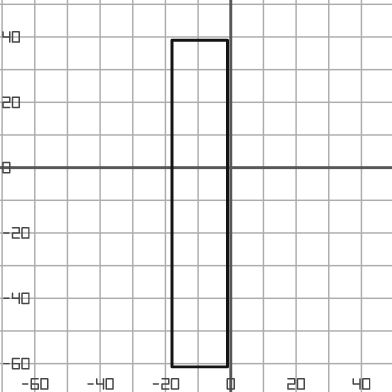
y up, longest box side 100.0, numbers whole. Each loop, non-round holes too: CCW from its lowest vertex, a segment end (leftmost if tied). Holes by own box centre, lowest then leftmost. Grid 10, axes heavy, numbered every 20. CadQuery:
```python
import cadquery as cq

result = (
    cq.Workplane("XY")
    .moveTo(-18.0, -61.0)
    .lineTo(-1.0, -61.0)
    .lineTo(-1.0, 39.0)
    .lineTo(-18.0, 39.0)
    .close()
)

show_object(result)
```